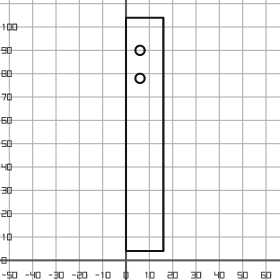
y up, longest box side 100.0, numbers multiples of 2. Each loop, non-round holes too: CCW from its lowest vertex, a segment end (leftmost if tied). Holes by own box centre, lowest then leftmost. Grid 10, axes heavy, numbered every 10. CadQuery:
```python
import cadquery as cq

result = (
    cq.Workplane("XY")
    .moveTo(0.0, 4.0)
    .lineTo(16.0, 4.0)
    .lineTo(16.0, 104.0)
    .lineTo(0.0, 104.0)
    .close()
    .moveTo(6.0, 78.0)
    .circle(2.0)
    .moveTo(6.0, 90.0)
    .circle(2.0)
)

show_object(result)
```